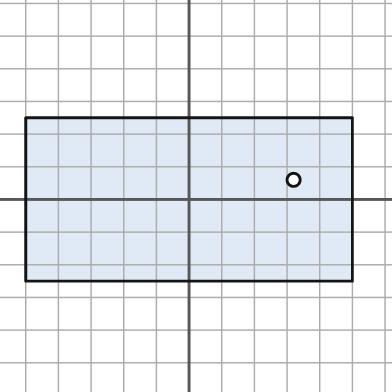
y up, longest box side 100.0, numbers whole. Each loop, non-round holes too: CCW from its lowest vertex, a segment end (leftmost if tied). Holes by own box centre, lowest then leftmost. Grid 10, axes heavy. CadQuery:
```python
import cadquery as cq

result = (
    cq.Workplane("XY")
    .moveTo(-50.0, -25.0)
    .lineTo(50.0, -25.0)
    .lineTo(50.0, 25.0)
    .lineTo(-50.0, 25.0)
    .close()
    .moveTo(32.0, 6.0)
    .circle(2.0)
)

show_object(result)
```